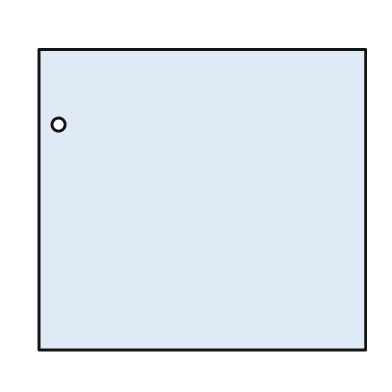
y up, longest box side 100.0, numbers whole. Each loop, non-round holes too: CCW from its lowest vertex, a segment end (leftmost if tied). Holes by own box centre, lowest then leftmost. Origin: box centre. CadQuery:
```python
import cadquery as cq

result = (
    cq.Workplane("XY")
    .moveTo(-50.0, -46.0)
    .lineTo(50.0, -46.0)
    .lineTo(50.0, 46.0)
    .lineTo(-50.0, 46.0)
    .close()
    .moveTo(-44.0, 23.0)
    .circle(2.0)
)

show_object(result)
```